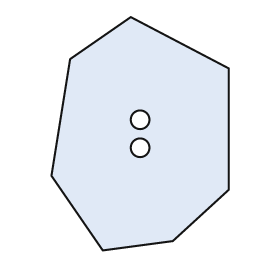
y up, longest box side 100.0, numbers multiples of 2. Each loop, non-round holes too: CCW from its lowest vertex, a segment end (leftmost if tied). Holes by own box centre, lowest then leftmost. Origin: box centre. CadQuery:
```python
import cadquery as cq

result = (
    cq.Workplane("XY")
    .moveTo(-16.0, -50.0)
    .lineTo(14.0, -46.0)
    .lineTo(38.0, -24.0)
    .lineTo(38.0, 28.0)
    .lineTo(-4.0, 50.0)
    .lineTo(-30.0, 32.0)
    .lineTo(-38.0, -18.0)
    .close()
    .moveTo(0.0, -6.0)
    .circle(4.0)
    .moveTo(0.0, 6.0)
    .circle(4.0)
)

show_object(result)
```